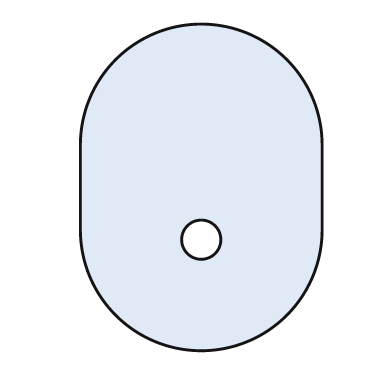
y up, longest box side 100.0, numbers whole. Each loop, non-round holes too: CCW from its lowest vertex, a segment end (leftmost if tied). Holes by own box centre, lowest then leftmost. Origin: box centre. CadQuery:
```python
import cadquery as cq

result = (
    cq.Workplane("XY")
    .moveTo(-37.0, -13.0)
    .threePointArc((0.0, -50.0), (37.0, -13.0))
    .lineTo(37.0, 13.0)
    .threePointArc((0.0, 50.0), (-37.0, 13.0))
    .close()
    .moveTo(0.0, -16.0)
    .circle(6.0)
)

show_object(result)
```